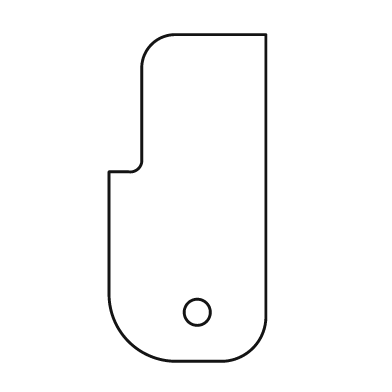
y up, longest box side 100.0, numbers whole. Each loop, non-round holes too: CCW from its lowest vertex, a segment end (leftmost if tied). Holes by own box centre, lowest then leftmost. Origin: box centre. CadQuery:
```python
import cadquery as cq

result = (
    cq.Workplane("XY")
    .moveTo(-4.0, -50.0)
    .lineTo(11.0, -50.0)
    .threePointArc((20.0, -46.0), (24.0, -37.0))
    .lineTo(24.0, 50.0)
    .lineTo(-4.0, 50.0)
    .threePointArc((-11.0, 47.0), (-14.0, 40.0))
    .lineTo(-14.0, 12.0)
    .threePointArc((-15.0, 9.0), (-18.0, 8.0))
    .lineTo(-24.0, 8.0)
    .lineTo(-24.0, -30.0)
    .threePointArc((-18.0, -44.0), (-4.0, -50.0))
    .close()
    .moveTo(3.0, -35.0)
    .circle(4.0)
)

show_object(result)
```